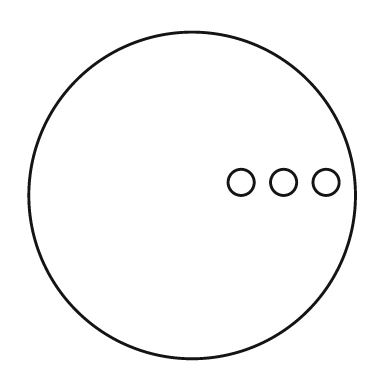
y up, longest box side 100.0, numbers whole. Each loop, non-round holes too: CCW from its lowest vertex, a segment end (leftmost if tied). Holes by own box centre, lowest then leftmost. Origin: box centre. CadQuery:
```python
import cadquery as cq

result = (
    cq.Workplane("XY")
    .moveTo(0.0, 0.0)
    .circle(50.0)
    .moveTo(15.0, 4.0)
    .circle(4.0)
    .moveTo(28.0, 4.0)
    .circle(4.0)
    .moveTo(41.0, 4.0)
    .circle(4.0)
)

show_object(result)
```